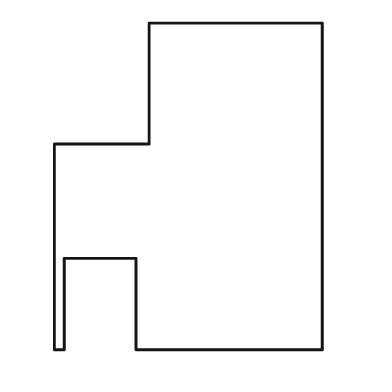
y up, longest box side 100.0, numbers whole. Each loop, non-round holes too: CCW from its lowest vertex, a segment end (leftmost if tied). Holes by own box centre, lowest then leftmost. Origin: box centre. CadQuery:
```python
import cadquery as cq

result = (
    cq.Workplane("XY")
    .moveTo(-41.0, -50.0)
    .lineTo(-38.0, -50.0)
    .lineTo(-38.0, -22.0)
    .lineTo(-16.0, -22.0)
    .lineTo(-16.0, -50.0)
    .lineTo(41.0, -50.0)
    .lineTo(41.0, 50.0)
    .lineTo(-12.0, 50.0)
    .lineTo(-12.0, 13.0)
    .lineTo(-41.0, 13.0)
    .close()
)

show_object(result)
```